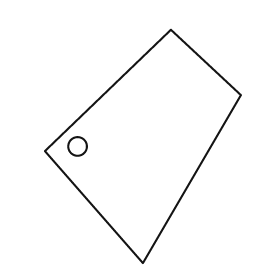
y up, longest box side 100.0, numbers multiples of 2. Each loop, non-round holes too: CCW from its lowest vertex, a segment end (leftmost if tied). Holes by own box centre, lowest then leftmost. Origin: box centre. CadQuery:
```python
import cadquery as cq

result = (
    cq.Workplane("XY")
    .moveTo(0.0, -50.0)
    .lineTo(42.0, 22.0)
    .lineTo(12.0, 50.0)
    .lineTo(-42.0, -2.0)
    .close()
    .moveTo(-28.0, 0.0)
    .circle(4.0)
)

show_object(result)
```